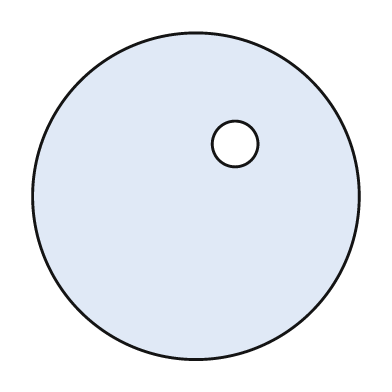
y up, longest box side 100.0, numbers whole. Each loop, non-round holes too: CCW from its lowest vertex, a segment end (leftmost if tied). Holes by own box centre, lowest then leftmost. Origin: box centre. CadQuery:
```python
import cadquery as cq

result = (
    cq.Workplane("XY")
    .moveTo(0.0, 0.0)
    .circle(50.0)
    .moveTo(12.0, 16.0)
    .circle(7.0)
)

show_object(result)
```